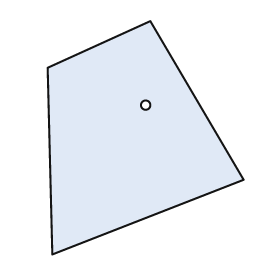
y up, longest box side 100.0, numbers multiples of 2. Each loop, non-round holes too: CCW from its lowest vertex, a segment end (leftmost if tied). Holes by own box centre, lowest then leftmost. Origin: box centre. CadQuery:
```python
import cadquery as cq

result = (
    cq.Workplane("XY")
    .moveTo(-40.0, -50.0)
    .lineTo(42.0, -18.0)
    .lineTo(2.0, 50.0)
    .lineTo(-42.0, 30.0)
    .close()
    .moveTo(0.0, 14.0)
    .circle(2.0)
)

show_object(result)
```